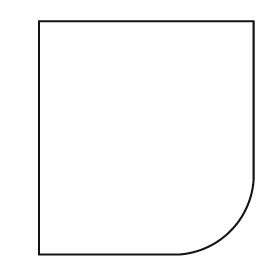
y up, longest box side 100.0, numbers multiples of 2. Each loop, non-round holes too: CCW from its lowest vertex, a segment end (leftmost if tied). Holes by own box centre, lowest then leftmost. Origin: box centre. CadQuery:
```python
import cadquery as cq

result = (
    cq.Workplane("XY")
    .moveTo(-46.0, -50.0)
    .lineTo(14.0, -50.0)
    .threePointArc((36.0, -40.0), (46.0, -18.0))
    .lineTo(46.0, 50.0)
    .lineTo(-46.0, 50.0)
    .close()
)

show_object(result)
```